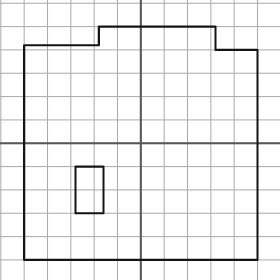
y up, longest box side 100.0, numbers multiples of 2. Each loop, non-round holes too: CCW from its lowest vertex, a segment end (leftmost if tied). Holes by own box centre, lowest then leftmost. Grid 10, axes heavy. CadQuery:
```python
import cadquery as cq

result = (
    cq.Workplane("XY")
    .moveTo(-50.0, -50.0)
    .lineTo(50.0, -50.0)
    .lineTo(50.0, 40.0)
    .lineTo(32.0, 40.0)
    .lineTo(32.0, 50.0)
    .lineTo(-18.0, 50.0)
    .lineTo(-18.0, 42.0)
    .lineTo(-50.0, 42.0)
    .close()
    .moveTo(-28.0, -30.0)
    .lineTo(-16.0, -30.0)
    .lineTo(-16.0, -10.0)
    .lineTo(-28.0, -10.0)
    .close()
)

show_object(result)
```